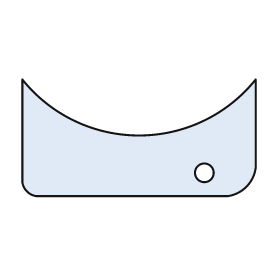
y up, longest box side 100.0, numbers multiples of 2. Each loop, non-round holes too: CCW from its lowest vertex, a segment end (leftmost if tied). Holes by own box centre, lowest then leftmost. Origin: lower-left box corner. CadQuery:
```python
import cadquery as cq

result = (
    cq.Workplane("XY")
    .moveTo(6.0, 0.0)
    .lineTo(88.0, 0.0)
    .threePointArc((96.0, 4.0), (100.0, 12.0))
    .lineTo(100.0, 50.0)
    .threePointArc((50.0, 26.0), (0.0, 50.0))
    .lineTo(0.0, 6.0)
    .threePointArc((2.0, 2.0), (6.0, 0.0))
    .close()
    .moveTo(78.0, 10.0)
    .circle(4.0)
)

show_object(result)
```